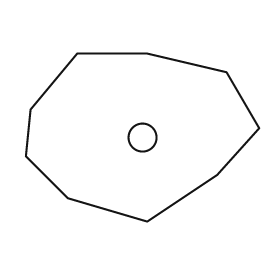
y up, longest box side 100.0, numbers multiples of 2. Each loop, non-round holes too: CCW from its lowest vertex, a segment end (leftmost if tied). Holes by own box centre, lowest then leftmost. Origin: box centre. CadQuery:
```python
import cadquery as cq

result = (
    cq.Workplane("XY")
    .moveTo(2.0, -36.0)
    .lineTo(32.0, -16.0)
    .lineTo(50.0, 4.0)
    .lineTo(36.0, 28.0)
    .lineTo(2.0, 36.0)
    .lineTo(-28.0, 36.0)
    .lineTo(-48.0, 12.0)
    .lineTo(-50.0, -8.0)
    .lineTo(-32.0, -26.0)
    .close()
    .moveTo(0.0, 0.0)
    .circle(6.0)
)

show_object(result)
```